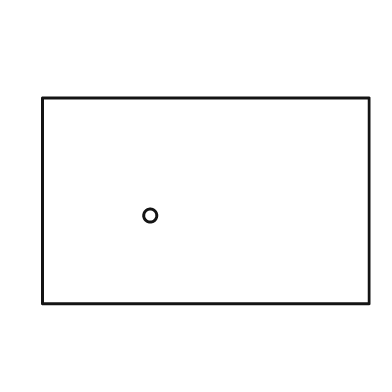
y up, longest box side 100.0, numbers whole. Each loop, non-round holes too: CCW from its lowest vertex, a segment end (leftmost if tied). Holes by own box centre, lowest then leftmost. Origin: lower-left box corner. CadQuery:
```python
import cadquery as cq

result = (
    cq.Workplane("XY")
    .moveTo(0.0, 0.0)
    .lineTo(100.0, 0.0)
    .lineTo(100.0, 63.0)
    .lineTo(0.0, 63.0)
    .close()
    .moveTo(33.0, 27.0)
    .circle(2.0)
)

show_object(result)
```